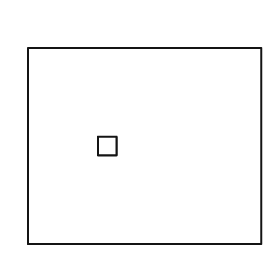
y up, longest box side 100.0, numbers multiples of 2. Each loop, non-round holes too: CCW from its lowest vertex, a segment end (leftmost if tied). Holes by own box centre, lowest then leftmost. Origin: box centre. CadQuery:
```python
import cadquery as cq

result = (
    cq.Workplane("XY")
    .moveTo(-50.0, -42.0)
    .lineTo(50.0, -42.0)
    .lineTo(50.0, 42.0)
    .lineTo(-50.0, 42.0)
    .close()
    .moveTo(-20.0, -4.0)
    .lineTo(-12.0, -4.0)
    .lineTo(-12.0, 4.0)
    .lineTo(-20.0, 4.0)
    .close()
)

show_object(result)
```